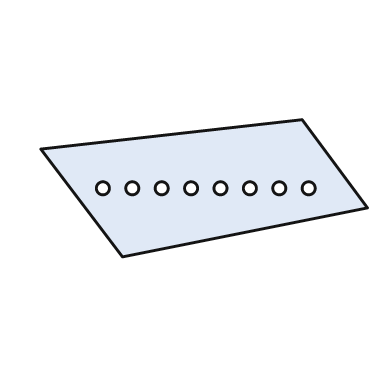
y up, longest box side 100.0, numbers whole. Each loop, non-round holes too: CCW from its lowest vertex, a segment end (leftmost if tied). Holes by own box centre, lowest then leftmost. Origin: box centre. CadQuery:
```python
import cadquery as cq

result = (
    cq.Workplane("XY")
    .moveTo(-25.0, -21.0)
    .lineTo(50.0, -6.0)
    .lineTo(30.0, 21.0)
    .lineTo(-50.0, 12.0)
    .close()
    .moveTo(-31.0, 0.0)
    .circle(2.0)
    .moveTo(-22.0, 0.0)
    .circle(2.0)
    .moveTo(-13.0, 0.0)
    .circle(2.0)
    .moveTo(-4.0, 0.0)
    .circle(2.0)
    .moveTo(5.0, 0.0)
    .circle(2.0)
    .moveTo(14.0, 0.0)
    .circle(2.0)
    .moveTo(23.0, 0.0)
    .circle(2.0)
    .moveTo(32.0, 0.0)
    .circle(2.0)
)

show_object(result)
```